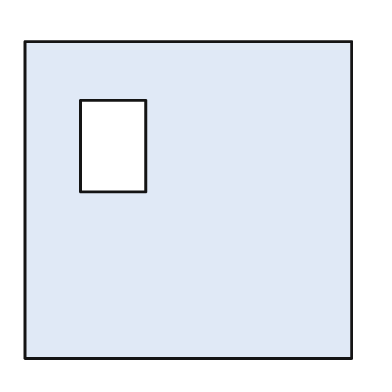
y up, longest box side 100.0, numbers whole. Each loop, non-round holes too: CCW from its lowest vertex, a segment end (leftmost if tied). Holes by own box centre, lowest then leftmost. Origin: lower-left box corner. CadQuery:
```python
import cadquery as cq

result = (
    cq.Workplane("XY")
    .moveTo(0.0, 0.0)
    .lineTo(100.0, 0.0)
    .lineTo(100.0, 97.0)
    .lineTo(0.0, 97.0)
    .close()
    .moveTo(17.0, 51.0)
    .lineTo(37.0, 51.0)
    .lineTo(37.0, 79.0)
    .lineTo(17.0, 79.0)
    .close()
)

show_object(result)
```